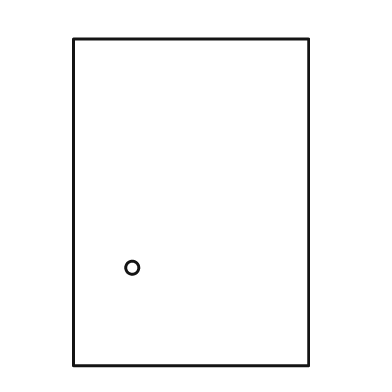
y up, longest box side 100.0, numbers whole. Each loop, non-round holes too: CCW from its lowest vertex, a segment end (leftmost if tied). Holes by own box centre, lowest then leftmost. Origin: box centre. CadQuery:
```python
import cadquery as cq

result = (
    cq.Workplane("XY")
    .moveTo(-36.0, -50.0)
    .lineTo(36.0, -50.0)
    .lineTo(36.0, 50.0)
    .lineTo(-36.0, 50.0)
    .close()
    .moveTo(-18.0, -20.0)
    .circle(2.0)
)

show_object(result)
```